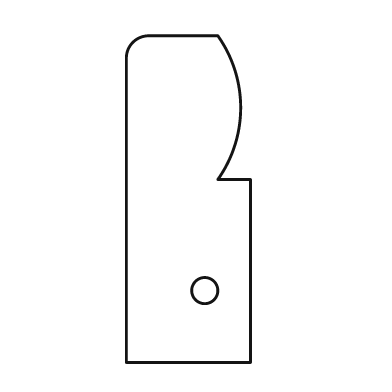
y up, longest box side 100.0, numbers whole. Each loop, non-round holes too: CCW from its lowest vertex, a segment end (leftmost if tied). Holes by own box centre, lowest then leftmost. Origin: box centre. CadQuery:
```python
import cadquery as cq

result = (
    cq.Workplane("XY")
    .moveTo(-19.0, -50.0)
    .lineTo(19.0, -50.0)
    .lineTo(19.0, 6.0)
    .lineTo(9.0, 6.0)
    .threePointArc((16.0, 28.0), (9.0, 50.0))
    .lineTo(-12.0, 50.0)
    .threePointArc((-17.0, 48.0), (-19.0, 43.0))
    .close()
    .moveTo(5.0, -28.0)
    .circle(4.0)
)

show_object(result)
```